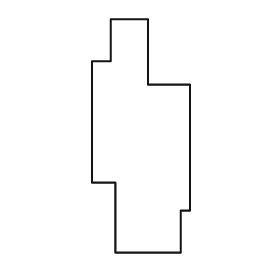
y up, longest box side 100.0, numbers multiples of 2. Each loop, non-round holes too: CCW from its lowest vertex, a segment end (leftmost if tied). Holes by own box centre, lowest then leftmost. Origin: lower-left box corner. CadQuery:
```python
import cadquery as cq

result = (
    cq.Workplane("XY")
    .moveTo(10.0, 0.0)
    .lineTo(38.0, 0.0)
    .lineTo(38.0, 18.0)
    .lineTo(42.0, 18.0)
    .lineTo(42.0, 72.0)
    .lineTo(24.0, 72.0)
    .lineTo(24.0, 100.0)
    .lineTo(8.0, 100.0)
    .lineTo(8.0, 82.0)
    .lineTo(0.0, 82.0)
    .lineTo(0.0, 30.0)
    .lineTo(10.0, 30.0)
    .close()
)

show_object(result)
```